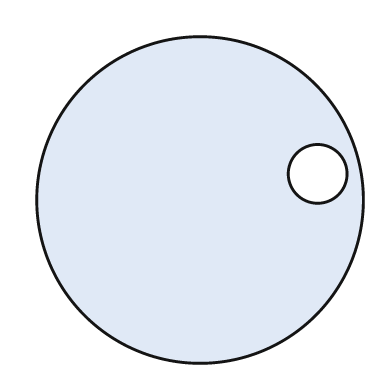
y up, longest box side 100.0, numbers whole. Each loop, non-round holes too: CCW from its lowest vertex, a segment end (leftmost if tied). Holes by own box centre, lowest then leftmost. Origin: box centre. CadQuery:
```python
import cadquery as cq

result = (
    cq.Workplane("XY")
    .moveTo(0.0, 0.0)
    .circle(50.0)
    .moveTo(36.0, 8.0)
    .circle(9.0)
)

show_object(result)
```